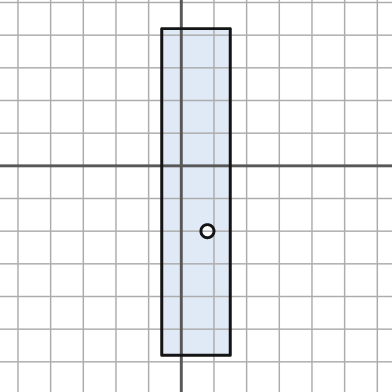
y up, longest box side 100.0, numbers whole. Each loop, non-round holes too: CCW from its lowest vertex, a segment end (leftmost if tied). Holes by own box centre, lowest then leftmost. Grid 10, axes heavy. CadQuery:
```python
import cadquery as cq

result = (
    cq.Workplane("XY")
    .moveTo(-6.0, -58.0)
    .lineTo(15.0, -58.0)
    .lineTo(15.0, 42.0)
    .lineTo(-6.0, 42.0)
    .close()
    .moveTo(8.0, -20.0)
    .circle(2.0)
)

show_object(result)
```